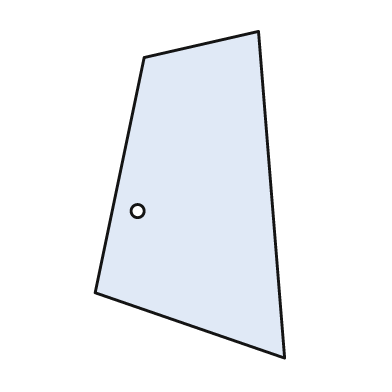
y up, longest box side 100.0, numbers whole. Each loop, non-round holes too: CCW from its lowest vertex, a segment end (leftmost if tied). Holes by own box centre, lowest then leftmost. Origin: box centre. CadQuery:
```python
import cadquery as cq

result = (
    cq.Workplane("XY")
    .moveTo(29.0, -50.0)
    .lineTo(21.0, 50.0)
    .lineTo(-14.0, 42.0)
    .lineTo(-29.0, -30.0)
    .close()
    .moveTo(-16.0, -5.0)
    .circle(2.0)
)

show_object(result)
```